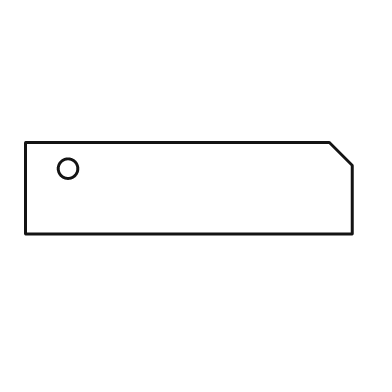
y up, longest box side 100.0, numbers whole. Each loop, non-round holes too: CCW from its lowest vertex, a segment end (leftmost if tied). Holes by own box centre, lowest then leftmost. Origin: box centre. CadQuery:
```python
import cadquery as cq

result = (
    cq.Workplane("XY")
    .moveTo(-50.0, -14.0)
    .lineTo(50.0, -14.0)
    .lineTo(50.0, 7.0)
    .lineTo(43.0, 14.0)
    .lineTo(-50.0, 14.0)
    .close()
    .moveTo(-37.0, 6.0)
    .circle(3.0)
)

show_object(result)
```